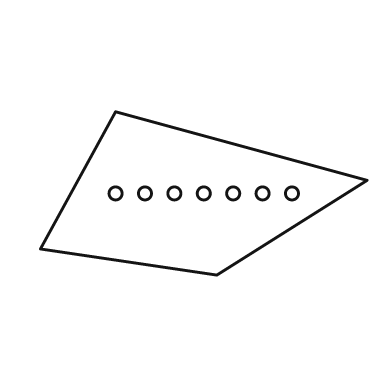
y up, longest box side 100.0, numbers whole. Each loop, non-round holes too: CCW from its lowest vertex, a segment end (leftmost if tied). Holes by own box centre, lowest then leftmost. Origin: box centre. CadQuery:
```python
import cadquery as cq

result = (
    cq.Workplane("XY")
    .moveTo(4.0, -25.0)
    .lineTo(50.0, 4.0)
    .lineTo(-27.0, 25.0)
    .lineTo(-50.0, -17.0)
    .close()
    .moveTo(-27.0, 0.0)
    .circle(2.0)
    .moveTo(-18.0, 0.0)
    .circle(2.0)
    .moveTo(-9.0, 0.0)
    .circle(2.0)
    .moveTo(0.0, 0.0)
    .circle(2.0)
    .moveTo(9.0, 0.0)
    .circle(2.0)
    .moveTo(18.0, 0.0)
    .circle(2.0)
    .moveTo(27.0, 0.0)
    .circle(2.0)
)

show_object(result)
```